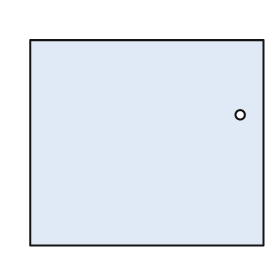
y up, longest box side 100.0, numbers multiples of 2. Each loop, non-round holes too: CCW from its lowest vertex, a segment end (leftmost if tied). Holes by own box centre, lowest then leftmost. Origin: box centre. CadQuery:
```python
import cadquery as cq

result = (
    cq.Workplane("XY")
    .moveTo(-50.0, -44.0)
    .lineTo(50.0, -44.0)
    .lineTo(50.0, 44.0)
    .lineTo(-50.0, 44.0)
    .close()
    .moveTo(40.0, 12.0)
    .circle(2.0)
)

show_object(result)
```